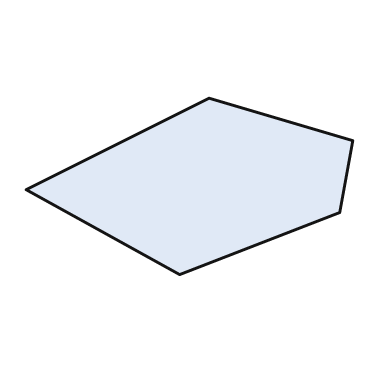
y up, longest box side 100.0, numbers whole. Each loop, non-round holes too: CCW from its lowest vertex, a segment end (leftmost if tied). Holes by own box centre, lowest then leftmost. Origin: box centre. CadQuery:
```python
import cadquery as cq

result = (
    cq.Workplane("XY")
    .moveTo(-3.0, -27.0)
    .lineTo(46.0, -8.0)
    .lineTo(50.0, 14.0)
    .lineTo(6.0, 27.0)
    .lineTo(-50.0, -1.0)
    .close()
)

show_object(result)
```